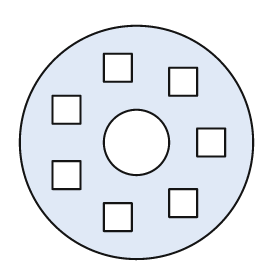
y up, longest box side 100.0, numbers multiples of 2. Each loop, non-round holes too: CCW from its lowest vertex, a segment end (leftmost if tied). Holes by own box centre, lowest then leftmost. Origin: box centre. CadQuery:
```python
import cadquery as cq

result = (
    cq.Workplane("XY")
    .moveTo(0.0, 0.0)
    .circle(50.0)
    .moveTo(-14.0, -38.0)
    .lineTo(-2.0, -38.0)
    .lineTo(-2.0, -26.0)
    .lineTo(-14.0, -26.0)
    .close()
    .moveTo(14.0, -32.0)
    .lineTo(26.0, -32.0)
    .lineTo(26.0, -20.0)
    .lineTo(14.0, -20.0)
    .close()
    .moveTo(-36.0, -20.0)
    .lineTo(-24.0, -20.0)
    .lineTo(-24.0, -8.0)
    .lineTo(-36.0, -8.0)
    .close()
    .moveTo(0.0, 0.0)
    .circle(14.0)
    .moveTo(26.0, -6.0)
    .lineTo(38.0, -6.0)
    .lineTo(38.0, 6.0)
    .lineTo(26.0, 6.0)
    .close()
    .moveTo(-36.0, 8.0)
    .lineTo(-24.0, 8.0)
    .lineTo(-24.0, 20.0)
    .lineTo(-36.0, 20.0)
    .close()
    .moveTo(14.0, 20.0)
    .lineTo(26.0, 20.0)
    .lineTo(26.0, 32.0)
    .lineTo(14.0, 32.0)
    .close()
    .moveTo(-14.0, 26.0)
    .lineTo(-2.0, 26.0)
    .lineTo(-2.0, 38.0)
    .lineTo(-14.0, 38.0)
    .close()
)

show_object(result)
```